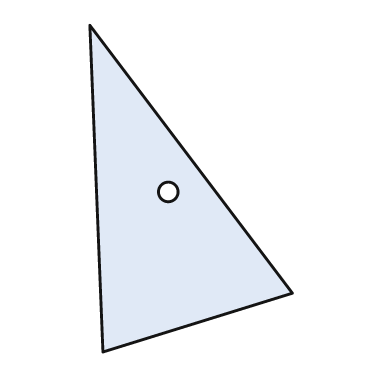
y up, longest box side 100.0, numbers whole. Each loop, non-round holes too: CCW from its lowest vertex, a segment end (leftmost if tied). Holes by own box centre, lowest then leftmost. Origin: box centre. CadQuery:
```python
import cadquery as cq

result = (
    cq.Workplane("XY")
    .moveTo(-27.0, -50.0)
    .lineTo(31.0, -32.0)
    .lineTo(-31.0, 50.0)
    .close()
    .moveTo(-7.0, -1.0)
    .circle(3.0)
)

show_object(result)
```